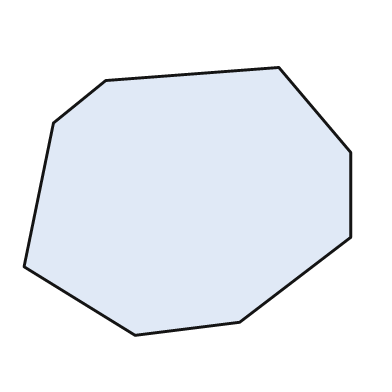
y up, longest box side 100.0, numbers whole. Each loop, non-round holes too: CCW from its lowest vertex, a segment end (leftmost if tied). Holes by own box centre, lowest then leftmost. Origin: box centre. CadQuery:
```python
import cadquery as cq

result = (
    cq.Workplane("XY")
    .moveTo(-16.0, -41.0)
    .lineTo(16.0, -37.0)
    .lineTo(50.0, -11.0)
    .lineTo(50.0, 15.0)
    .lineTo(28.0, 41.0)
    .lineTo(-25.0, 37.0)
    .lineTo(-41.0, 24.0)
    .lineTo(-50.0, -20.0)
    .close()
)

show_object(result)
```